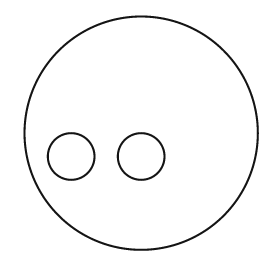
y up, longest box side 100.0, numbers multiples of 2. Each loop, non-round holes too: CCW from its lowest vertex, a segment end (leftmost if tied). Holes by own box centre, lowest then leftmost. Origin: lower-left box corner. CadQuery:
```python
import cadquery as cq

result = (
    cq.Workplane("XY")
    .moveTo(50.0, 50.0)
    .circle(50.0)
    .moveTo(20.0, 40.0)
    .circle(10.0)
    .moveTo(50.0, 40.0)
    .circle(10.0)
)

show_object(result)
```